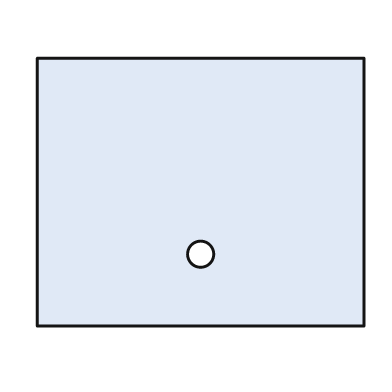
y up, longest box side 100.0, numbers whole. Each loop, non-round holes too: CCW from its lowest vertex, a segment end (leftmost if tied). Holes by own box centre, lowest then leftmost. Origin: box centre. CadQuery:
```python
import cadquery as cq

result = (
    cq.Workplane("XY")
    .moveTo(-50.0, -41.0)
    .lineTo(50.0, -41.0)
    .lineTo(50.0, 41.0)
    .lineTo(-50.0, 41.0)
    .close()
    .moveTo(0.0, -19.0)
    .circle(4.0)
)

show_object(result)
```